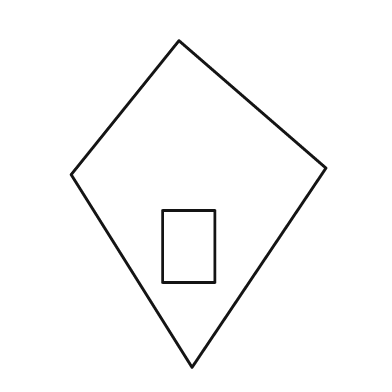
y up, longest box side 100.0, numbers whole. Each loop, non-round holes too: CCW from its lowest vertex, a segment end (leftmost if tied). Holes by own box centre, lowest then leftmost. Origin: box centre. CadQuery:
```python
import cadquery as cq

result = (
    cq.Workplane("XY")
    .moveTo(-2.0, -50.0)
    .lineTo(39.0, 11.0)
    .lineTo(-6.0, 50.0)
    .lineTo(-39.0, 9.0)
    .close()
    .moveTo(-11.0, -24.0)
    .lineTo(5.0, -24.0)
    .lineTo(5.0, -2.0)
    .lineTo(-11.0, -2.0)
    .close()
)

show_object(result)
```